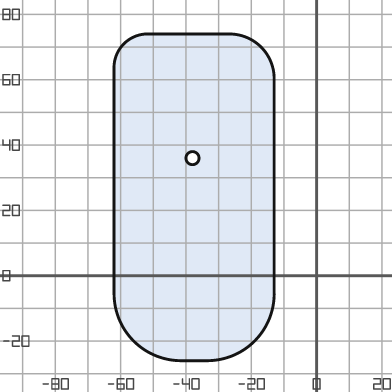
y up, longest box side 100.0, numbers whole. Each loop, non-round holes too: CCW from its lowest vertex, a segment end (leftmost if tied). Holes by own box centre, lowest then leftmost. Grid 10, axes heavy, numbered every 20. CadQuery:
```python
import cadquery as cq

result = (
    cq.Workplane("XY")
    .moveTo(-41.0, -26.0)
    .lineTo(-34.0, -26.0)
    .threePointArc((-19.0, -20.0), (-13.0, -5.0))
    .lineTo(-13.0, 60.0)
    .threePointArc((-17.0, 70.0), (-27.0, 74.0))
    .lineTo(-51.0, 74.0)
    .threePointArc((-59.0, 71.0), (-62.0, 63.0))
    .lineTo(-62.0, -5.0)
    .threePointArc((-56.0, -20.0), (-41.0, -26.0))
    .close()
    .moveTo(-38.0, 36.0)
    .circle(2.0)
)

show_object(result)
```